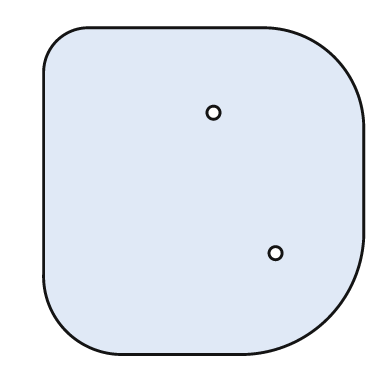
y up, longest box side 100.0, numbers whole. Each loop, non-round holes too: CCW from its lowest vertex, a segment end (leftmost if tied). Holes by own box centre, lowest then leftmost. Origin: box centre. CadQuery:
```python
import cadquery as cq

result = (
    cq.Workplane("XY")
    .moveTo(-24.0, -50.0)
    .lineTo(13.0, -50.0)
    .threePointArc((38.0, -39.0), (49.0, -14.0))
    .lineTo(49.0, 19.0)
    .threePointArc((40.0, 41.0), (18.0, 50.0))
    .lineTo(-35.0, 50.0)
    .threePointArc((-45.0, 46.0), (-49.0, 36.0))
    .lineTo(-49.0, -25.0)
    .threePointArc((-42.0, -43.0), (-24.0, -50.0))
    .close()
    .moveTo(22.0, -19.0)
    .circle(2.0)
    .moveTo(3.0, 24.0)
    .circle(2.0)
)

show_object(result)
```